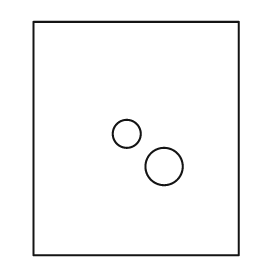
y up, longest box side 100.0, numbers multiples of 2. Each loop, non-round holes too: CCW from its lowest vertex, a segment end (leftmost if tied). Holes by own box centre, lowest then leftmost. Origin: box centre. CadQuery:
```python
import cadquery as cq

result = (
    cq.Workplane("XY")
    .moveTo(-44.0, -50.0)
    .lineTo(44.0, -50.0)
    .lineTo(44.0, 50.0)
    .lineTo(-44.0, 50.0)
    .close()
    .moveTo(12.0, -12.0)
    .circle(8.0)
    .moveTo(-4.0, 2.0)
    .circle(6.0)
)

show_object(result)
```